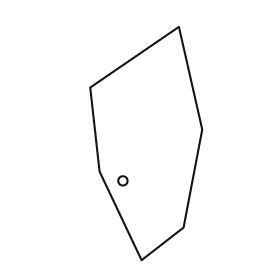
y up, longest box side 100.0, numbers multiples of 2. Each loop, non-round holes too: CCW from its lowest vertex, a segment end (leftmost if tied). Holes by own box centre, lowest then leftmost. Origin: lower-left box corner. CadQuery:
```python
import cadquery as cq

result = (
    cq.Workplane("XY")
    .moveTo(22.0, 0.0)
    .lineTo(40.0, 14.0)
    .lineTo(48.0, 56.0)
    .lineTo(38.0, 100.0)
    .lineTo(0.0, 74.0)
    .lineTo(4.0, 38.0)
    .close()
    .moveTo(14.0, 34.0)
    .circle(2.0)
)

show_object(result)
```